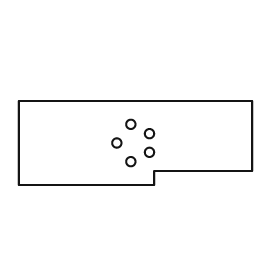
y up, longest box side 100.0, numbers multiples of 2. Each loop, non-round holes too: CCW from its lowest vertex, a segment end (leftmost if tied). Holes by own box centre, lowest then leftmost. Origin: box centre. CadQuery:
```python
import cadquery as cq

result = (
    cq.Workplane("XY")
    .moveTo(-50.0, -18.0)
    .lineTo(8.0, -18.0)
    .lineTo(8.0, -12.0)
    .lineTo(50.0, -12.0)
    .lineTo(50.0, 18.0)
    .lineTo(-50.0, 18.0)
    .close()
    .moveTo(-2.0, -8.0)
    .circle(2.0)
    .moveTo(6.0, -4.0)
    .circle(2.0)
    .moveTo(-8.0, 0.0)
    .circle(2.0)
    .moveTo(6.0, 4.0)
    .circle(2.0)
    .moveTo(-2.0, 8.0)
    .circle(2.0)
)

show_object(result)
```